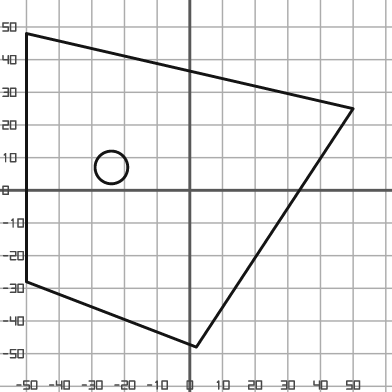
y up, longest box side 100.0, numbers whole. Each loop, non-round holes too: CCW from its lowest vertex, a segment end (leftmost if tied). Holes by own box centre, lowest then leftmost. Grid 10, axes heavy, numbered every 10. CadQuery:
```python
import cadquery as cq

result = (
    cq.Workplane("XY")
    .moveTo(2.0, -48.0)
    .lineTo(50.0, 25.0)
    .lineTo(-50.0, 48.0)
    .lineTo(-50.0, -28.0)
    .close()
    .moveTo(-24.0, 7.0)
    .circle(5.0)
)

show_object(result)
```